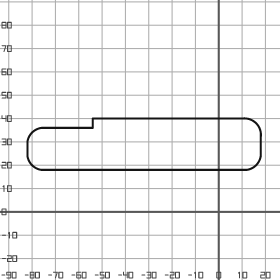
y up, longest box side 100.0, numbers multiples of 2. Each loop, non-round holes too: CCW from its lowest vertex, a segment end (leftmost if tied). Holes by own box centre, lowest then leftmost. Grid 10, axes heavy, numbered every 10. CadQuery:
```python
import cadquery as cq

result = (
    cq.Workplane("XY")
    .moveTo(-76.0, 18.0)
    .lineTo(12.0, 18.0)
    .threePointArc((16.0, 20.0), (18.0, 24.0))
    .lineTo(18.0, 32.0)
    .threePointArc((16.0, 38.0), (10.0, 40.0))
    .lineTo(-54.0, 40.0)
    .lineTo(-54.0, 36.0)
    .lineTo(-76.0, 36.0)
    .threePointArc((-80.0, 34.0), (-82.0, 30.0))
    .lineTo(-82.0, 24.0)
    .threePointArc((-80.0, 20.0), (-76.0, 18.0))
    .close()
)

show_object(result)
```